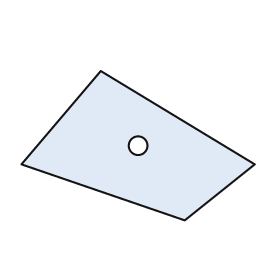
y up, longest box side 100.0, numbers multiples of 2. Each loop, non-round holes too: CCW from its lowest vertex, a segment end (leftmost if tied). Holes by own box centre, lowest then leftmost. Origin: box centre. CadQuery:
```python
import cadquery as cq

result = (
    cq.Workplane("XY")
    .moveTo(20.0, -32.0)
    .lineTo(50.0, -8.0)
    .lineTo(-16.0, 32.0)
    .lineTo(-50.0, -8.0)
    .close()
    .moveTo(0.0, 0.0)
    .circle(4.0)
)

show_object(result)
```